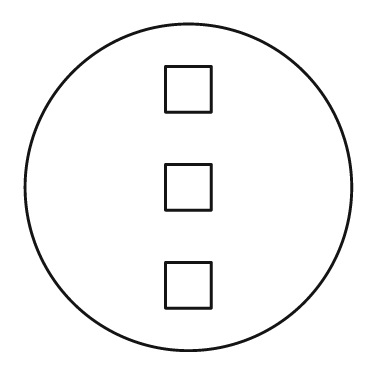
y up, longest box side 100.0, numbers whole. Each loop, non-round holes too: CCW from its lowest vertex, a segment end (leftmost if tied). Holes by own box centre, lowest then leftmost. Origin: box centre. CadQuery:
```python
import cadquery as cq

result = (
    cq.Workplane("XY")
    .moveTo(0.0, 0.0)
    .circle(50.0)
    .moveTo(-7.0, -37.0)
    .lineTo(7.0, -37.0)
    .lineTo(7.0, -23.0)
    .lineTo(-7.0, -23.0)
    .close()
    .moveTo(-7.0, -7.0)
    .lineTo(7.0, -7.0)
    .lineTo(7.0, 7.0)
    .lineTo(-7.0, 7.0)
    .close()
    .moveTo(-7.0, 23.0)
    .lineTo(7.0, 23.0)
    .lineTo(7.0, 37.0)
    .lineTo(-7.0, 37.0)
    .close()
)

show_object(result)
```